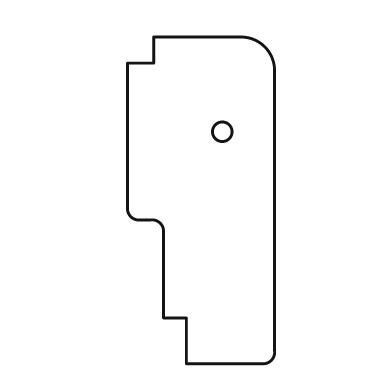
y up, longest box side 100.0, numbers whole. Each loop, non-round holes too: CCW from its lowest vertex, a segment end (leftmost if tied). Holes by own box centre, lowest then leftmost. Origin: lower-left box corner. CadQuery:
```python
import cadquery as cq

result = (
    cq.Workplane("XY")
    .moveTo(18.0, 0.0)
    .lineTo(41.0, 0.0)
    .threePointArc((44.0, 1.0), (45.0, 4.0))
    .lineTo(45.0, 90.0)
    .threePointArc((42.0, 97.0), (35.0, 100.0))
    .lineTo(8.0, 100.0)
    .lineTo(8.0, 92.0)
    .lineTo(0.0, 92.0)
    .lineTo(0.0, 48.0)
    .threePointArc((1.0, 45.0), (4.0, 44.0))
    .lineTo(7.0, 44.0)
    .threePointArc((10.0, 43.0), (11.0, 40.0))
    .lineTo(11.0, 14.0)
    .lineTo(18.0, 14.0)
    .close()
    .moveTo(29.0, 71.0)
    .circle(3.0)
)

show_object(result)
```